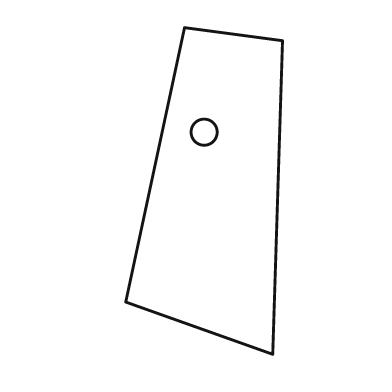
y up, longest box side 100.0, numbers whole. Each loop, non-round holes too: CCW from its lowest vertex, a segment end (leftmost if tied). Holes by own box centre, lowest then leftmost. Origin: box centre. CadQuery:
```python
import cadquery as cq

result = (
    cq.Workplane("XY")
    .moveTo(21.0, -50.0)
    .lineTo(24.0, 46.0)
    .lineTo(-6.0, 50.0)
    .lineTo(-24.0, -34.0)
    .close()
    .moveTo(0.0, 18.0)
    .circle(4.0)
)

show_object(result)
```